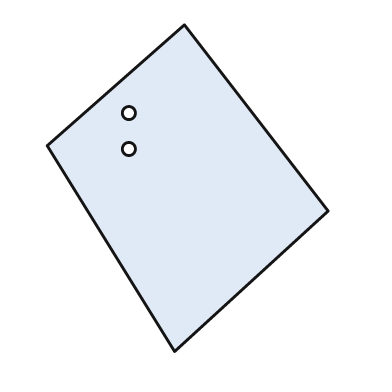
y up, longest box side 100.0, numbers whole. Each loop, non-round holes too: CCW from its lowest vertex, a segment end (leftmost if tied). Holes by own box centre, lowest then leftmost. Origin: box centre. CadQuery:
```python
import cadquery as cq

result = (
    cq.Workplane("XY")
    .moveTo(-4.0, -50.0)
    .lineTo(43.0, -7.0)
    .lineTo(-1.0, 50.0)
    .lineTo(-43.0, 13.0)
    .close()
    .moveTo(-18.0, 12.0)
    .circle(2.0)
    .moveTo(-18.0, 23.0)
    .circle(2.0)
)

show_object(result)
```